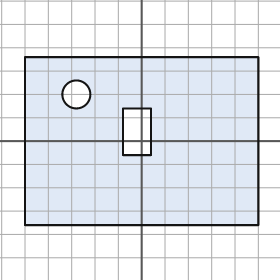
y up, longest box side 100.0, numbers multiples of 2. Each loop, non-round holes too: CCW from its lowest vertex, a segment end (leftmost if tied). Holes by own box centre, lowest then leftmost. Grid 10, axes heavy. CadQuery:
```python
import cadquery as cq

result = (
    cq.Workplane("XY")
    .moveTo(-50.0, -36.0)
    .lineTo(50.0, -36.0)
    .lineTo(50.0, 36.0)
    .lineTo(-50.0, 36.0)
    .close()
    .moveTo(-8.0, -6.0)
    .lineTo(4.0, -6.0)
    .lineTo(4.0, 14.0)
    .lineTo(-8.0, 14.0)
    .close()
    .moveTo(-28.0, 20.0)
    .circle(6.0)
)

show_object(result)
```